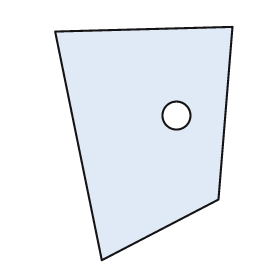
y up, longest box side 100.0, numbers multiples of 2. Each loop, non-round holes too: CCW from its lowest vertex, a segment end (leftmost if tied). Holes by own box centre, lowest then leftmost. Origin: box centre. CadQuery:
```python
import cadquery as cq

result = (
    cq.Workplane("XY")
    .moveTo(-18.0, -50.0)
    .lineTo(32.0, -24.0)
    .lineTo(38.0, 50.0)
    .lineTo(-38.0, 48.0)
    .close()
    .moveTo(14.0, 12.0)
    .circle(6.0)
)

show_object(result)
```